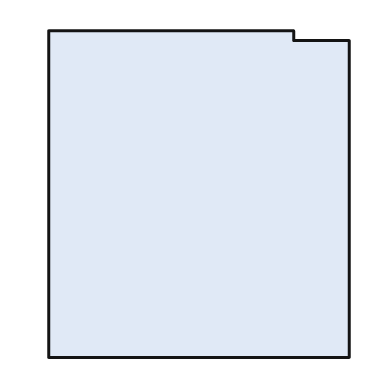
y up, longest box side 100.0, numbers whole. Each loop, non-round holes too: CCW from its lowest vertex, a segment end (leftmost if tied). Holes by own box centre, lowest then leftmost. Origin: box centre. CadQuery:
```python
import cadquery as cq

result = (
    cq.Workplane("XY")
    .moveTo(-46.0, -50.0)
    .lineTo(46.0, -50.0)
    .lineTo(46.0, 47.0)
    .lineTo(29.0, 47.0)
    .lineTo(29.0, 50.0)
    .lineTo(-46.0, 50.0)
    .close()
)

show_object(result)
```